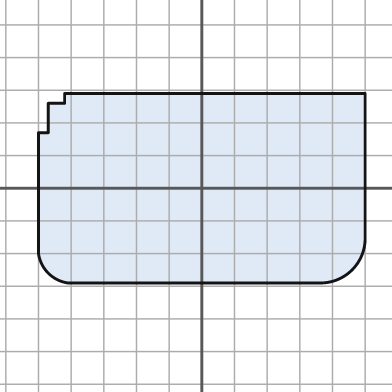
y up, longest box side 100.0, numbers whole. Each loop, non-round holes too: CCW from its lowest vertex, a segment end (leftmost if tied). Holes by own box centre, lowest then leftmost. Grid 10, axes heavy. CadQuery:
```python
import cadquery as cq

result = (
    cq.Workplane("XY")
    .moveTo(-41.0, -29.0)
    .lineTo(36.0, -29.0)
    .threePointArc((46.0, -25.0), (50.0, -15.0))
    .lineTo(50.0, 29.0)
    .lineTo(-42.0, 29.0)
    .lineTo(-42.0, 26.0)
    .lineTo(-47.0, 26.0)
    .lineTo(-47.0, 17.0)
    .lineTo(-50.0, 17.0)
    .lineTo(-50.0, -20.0)
    .threePointArc((-47.0, -26.0), (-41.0, -29.0))
    .close()
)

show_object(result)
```